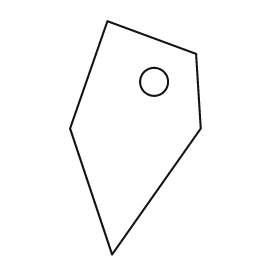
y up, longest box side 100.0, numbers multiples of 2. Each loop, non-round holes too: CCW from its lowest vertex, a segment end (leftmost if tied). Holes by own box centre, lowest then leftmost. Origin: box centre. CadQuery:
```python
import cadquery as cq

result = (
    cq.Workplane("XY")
    .moveTo(-10.0, -50.0)
    .lineTo(28.0, 4.0)
    .lineTo(26.0, 36.0)
    .lineTo(-12.0, 50.0)
    .lineTo(-28.0, 4.0)
    .close()
    .moveTo(8.0, 24.0)
    .circle(6.0)
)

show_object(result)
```